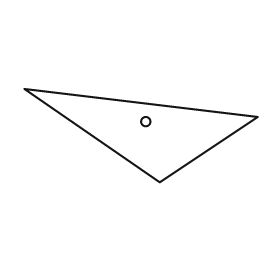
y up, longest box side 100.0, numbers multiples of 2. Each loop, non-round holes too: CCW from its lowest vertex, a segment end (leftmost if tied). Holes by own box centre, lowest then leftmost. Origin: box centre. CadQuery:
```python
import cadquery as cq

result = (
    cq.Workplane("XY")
    .moveTo(8.0, -20.0)
    .lineTo(50.0, 8.0)
    .lineTo(-50.0, 20.0)
    .close()
    .moveTo(2.0, 6.0)
    .circle(2.0)
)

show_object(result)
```